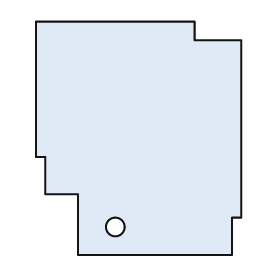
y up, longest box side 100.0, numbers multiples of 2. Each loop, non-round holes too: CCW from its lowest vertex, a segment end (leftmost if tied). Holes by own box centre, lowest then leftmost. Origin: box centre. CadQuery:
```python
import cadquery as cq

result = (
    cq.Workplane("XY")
    .moveTo(-26.0, -50.0)
    .lineTo(40.0, -50.0)
    .lineTo(40.0, -34.0)
    .lineTo(44.0, -34.0)
    .lineTo(44.0, 42.0)
    .lineTo(24.0, 42.0)
    .lineTo(24.0, 50.0)
    .lineTo(-44.0, 50.0)
    .lineTo(-44.0, -8.0)
    .lineTo(-40.0, -8.0)
    .lineTo(-40.0, -24.0)
    .lineTo(-26.0, -24.0)
    .close()
    .moveTo(-10.0, -38.0)
    .circle(4.0)
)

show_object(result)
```